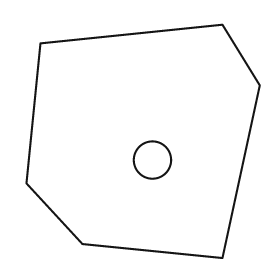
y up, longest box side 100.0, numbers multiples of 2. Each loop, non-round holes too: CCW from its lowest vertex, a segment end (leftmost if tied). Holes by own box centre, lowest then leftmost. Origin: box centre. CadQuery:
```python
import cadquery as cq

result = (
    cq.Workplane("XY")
    .moveTo(34.0, -50.0)
    .lineTo(50.0, 24.0)
    .lineTo(34.0, 50.0)
    .lineTo(-44.0, 42.0)
    .lineTo(-50.0, -18.0)
    .lineTo(-26.0, -44.0)
    .close()
    .moveTo(4.0, -8.0)
    .circle(8.0)
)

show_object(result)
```